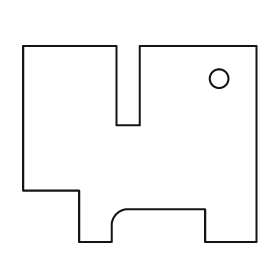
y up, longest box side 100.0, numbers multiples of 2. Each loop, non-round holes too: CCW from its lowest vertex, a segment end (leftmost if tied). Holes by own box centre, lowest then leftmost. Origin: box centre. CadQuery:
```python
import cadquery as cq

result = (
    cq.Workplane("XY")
    .moveTo(-26.0, -42.0)
    .lineTo(-12.0, -42.0)
    .lineTo(-12.0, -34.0)
    .threePointArc((-10.0, -30.0), (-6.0, -28.0))
    .lineTo(28.0, -28.0)
    .lineTo(28.0, -42.0)
    .lineTo(50.0, -42.0)
    .lineTo(50.0, 42.0)
    .lineTo(0.0, 42.0)
    .lineTo(0.0, 8.0)
    .lineTo(-10.0, 8.0)
    .lineTo(-10.0, 42.0)
    .lineTo(-50.0, 42.0)
    .lineTo(-50.0, -20.0)
    .lineTo(-26.0, -20.0)
    .close()
    .moveTo(34.0, 28.0)
    .circle(4.0)
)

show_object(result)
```